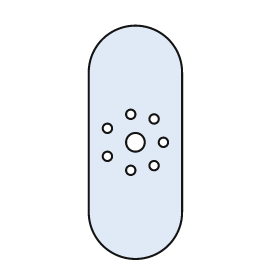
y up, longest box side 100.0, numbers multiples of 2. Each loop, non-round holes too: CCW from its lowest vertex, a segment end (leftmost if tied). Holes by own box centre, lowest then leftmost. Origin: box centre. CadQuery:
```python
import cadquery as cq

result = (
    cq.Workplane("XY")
    .moveTo(-20.0, -30.0)
    .threePointArc((0.0, -50.0), (20.0, -30.0))
    .lineTo(20.0, 30.0)
    .threePointArc((0.0, 50.0), (-20.0, 30.0))
    .close()
    .moveTo(-2.0, -12.0)
    .circle(2.0)
    .moveTo(8.0, -10.0)
    .circle(2.0)
    .moveTo(-12.0, -6.0)
    .circle(2.0)
    .moveTo(0.0, 0.0)
    .circle(4.0)
    .moveTo(12.0, 0.0)
    .circle(2.0)
    .moveTo(-12.0, 6.0)
    .circle(2.0)
    .moveTo(8.0, 10.0)
    .circle(2.0)
    .moveTo(-2.0, 12.0)
    .circle(2.0)
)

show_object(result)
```